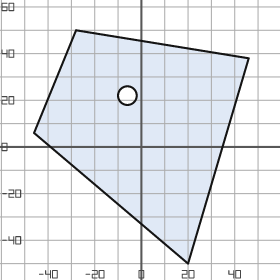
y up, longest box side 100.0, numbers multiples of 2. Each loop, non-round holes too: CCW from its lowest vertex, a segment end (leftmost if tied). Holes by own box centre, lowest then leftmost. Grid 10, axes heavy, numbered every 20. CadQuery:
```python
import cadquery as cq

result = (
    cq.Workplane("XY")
    .moveTo(20.0, -50.0)
    .lineTo(46.0, 38.0)
    .lineTo(-28.0, 50.0)
    .lineTo(-46.0, 6.0)
    .close()
    .moveTo(-6.0, 22.0)
    .circle(4.0)
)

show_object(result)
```